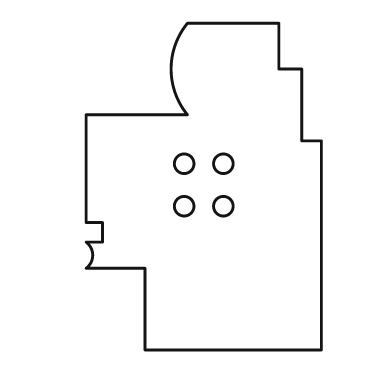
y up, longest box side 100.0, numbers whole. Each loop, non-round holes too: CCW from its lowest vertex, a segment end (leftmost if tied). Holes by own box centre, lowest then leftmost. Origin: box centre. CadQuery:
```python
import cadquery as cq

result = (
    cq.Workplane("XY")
    .moveTo(-18.0, -50.0)
    .lineTo(36.0, -50.0)
    .lineTo(36.0, 14.0)
    .lineTo(30.0, 14.0)
    .lineTo(30.0, 36.0)
    .lineTo(23.0, 36.0)
    .lineTo(23.0, 50.0)
    .lineTo(-5.0, 50.0)
    .threePointArc((-10.0, 36.0), (-5.0, 22.0))
    .lineTo(-36.0, 22.0)
    .lineTo(-36.0, -11.0)
    .lineTo(-31.0, -11.0)
    .lineTo(-31.0, -17.0)
    .lineTo(-36.0, -17.0)
    .threePointArc((-34.0, -21.0), (-36.0, -25.0))
    .lineTo(-18.0, -25.0)
    .close()
    .moveTo(-6.0, -6.0)
    .circle(3.0)
    .moveTo(6.0, -6.0)
    .circle(3.0)
    .moveTo(-6.0, 7.0)
    .circle(3.0)
    .moveTo(6.0, 7.0)
    .circle(3.0)
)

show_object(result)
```